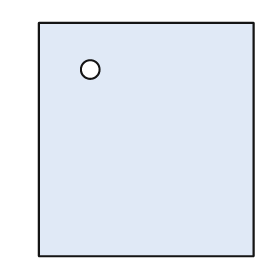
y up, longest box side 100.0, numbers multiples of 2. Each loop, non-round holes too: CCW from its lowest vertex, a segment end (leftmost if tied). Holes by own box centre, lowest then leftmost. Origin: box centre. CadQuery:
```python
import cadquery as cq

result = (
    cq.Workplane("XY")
    .moveTo(-46.0, -50.0)
    .lineTo(46.0, -50.0)
    .lineTo(46.0, 50.0)
    .lineTo(-46.0, 50.0)
    .close()
    .moveTo(-24.0, 30.0)
    .circle(4.0)
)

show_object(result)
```